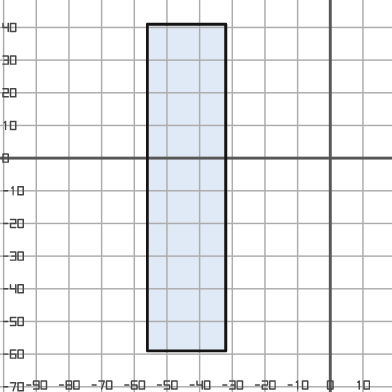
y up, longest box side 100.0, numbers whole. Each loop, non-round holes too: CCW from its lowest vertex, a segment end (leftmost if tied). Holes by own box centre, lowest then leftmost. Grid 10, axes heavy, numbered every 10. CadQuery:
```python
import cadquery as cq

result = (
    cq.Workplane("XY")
    .moveTo(-56.0, -59.0)
    .lineTo(-32.0, -59.0)
    .lineTo(-32.0, 41.0)
    .lineTo(-56.0, 41.0)
    .close()
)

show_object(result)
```